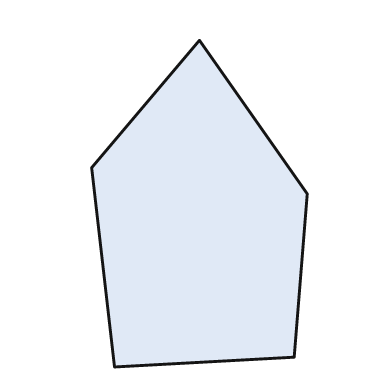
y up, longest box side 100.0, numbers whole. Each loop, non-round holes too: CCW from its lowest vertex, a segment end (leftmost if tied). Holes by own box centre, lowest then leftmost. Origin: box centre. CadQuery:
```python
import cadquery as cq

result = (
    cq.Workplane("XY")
    .moveTo(-26.0, -50.0)
    .lineTo(29.0, -47.0)
    .lineTo(33.0, 3.0)
    .lineTo(0.0, 50.0)
    .lineTo(-33.0, 11.0)
    .close()
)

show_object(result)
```